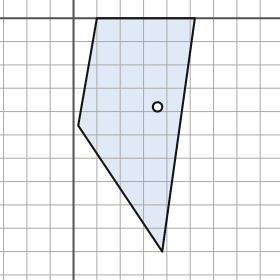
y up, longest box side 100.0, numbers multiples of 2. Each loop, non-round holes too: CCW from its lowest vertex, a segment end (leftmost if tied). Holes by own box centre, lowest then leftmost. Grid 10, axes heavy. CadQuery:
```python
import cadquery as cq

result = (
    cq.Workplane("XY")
    .moveTo(38.0, -100.0)
    .lineTo(52.0, 0.0)
    .lineTo(10.0, 0.0)
    .lineTo(2.0, -46.0)
    .close()
    .moveTo(36.0, -38.0)
    .circle(2.0)
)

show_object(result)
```